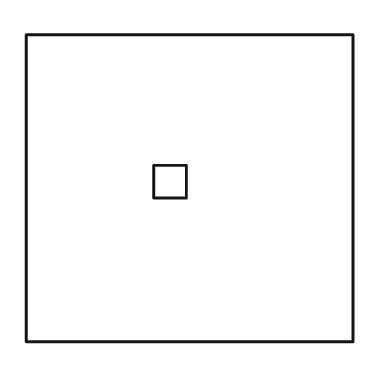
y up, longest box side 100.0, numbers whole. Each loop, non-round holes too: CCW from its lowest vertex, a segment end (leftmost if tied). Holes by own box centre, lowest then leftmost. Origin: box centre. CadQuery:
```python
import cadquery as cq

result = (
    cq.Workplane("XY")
    .moveTo(-50.0, -47.0)
    .lineTo(50.0, -47.0)
    .lineTo(50.0, 47.0)
    .lineTo(-50.0, 47.0)
    .close()
    .moveTo(-11.0, -3.0)
    .lineTo(-1.0, -3.0)
    .lineTo(-1.0, 7.0)
    .lineTo(-11.0, 7.0)
    .close()
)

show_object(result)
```